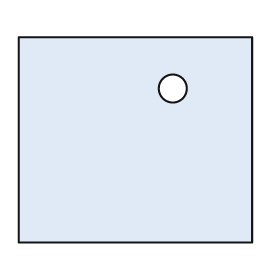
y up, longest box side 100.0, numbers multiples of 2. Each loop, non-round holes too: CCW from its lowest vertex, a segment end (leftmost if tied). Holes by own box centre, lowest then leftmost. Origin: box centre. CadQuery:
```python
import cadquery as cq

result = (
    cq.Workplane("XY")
    .moveTo(-50.0, -44.0)
    .lineTo(50.0, -44.0)
    .lineTo(50.0, 44.0)
    .lineTo(-50.0, 44.0)
    .close()
    .moveTo(16.0, 22.0)
    .circle(6.0)
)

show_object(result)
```